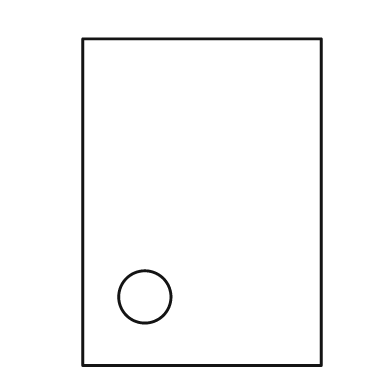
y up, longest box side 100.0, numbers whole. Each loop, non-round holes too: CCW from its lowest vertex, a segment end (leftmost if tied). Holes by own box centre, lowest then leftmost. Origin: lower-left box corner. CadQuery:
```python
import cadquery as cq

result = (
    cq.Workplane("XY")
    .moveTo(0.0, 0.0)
    .lineTo(73.0, 0.0)
    .lineTo(73.0, 100.0)
    .lineTo(0.0, 100.0)
    .close()
    .moveTo(19.0, 21.0)
    .circle(8.0)
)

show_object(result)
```